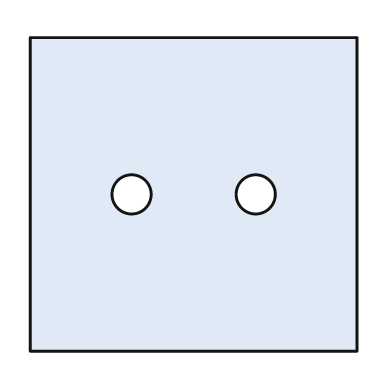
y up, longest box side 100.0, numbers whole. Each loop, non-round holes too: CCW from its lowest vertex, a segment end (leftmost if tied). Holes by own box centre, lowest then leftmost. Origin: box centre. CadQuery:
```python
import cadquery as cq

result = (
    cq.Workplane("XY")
    .moveTo(-50.0, -48.0)
    .lineTo(50.0, -48.0)
    .lineTo(50.0, 48.0)
    .lineTo(-50.0, 48.0)
    .close()
    .moveTo(-19.0, 0.0)
    .circle(6.0)
    .moveTo(19.0, 0.0)
    .circle(6.0)
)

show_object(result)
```